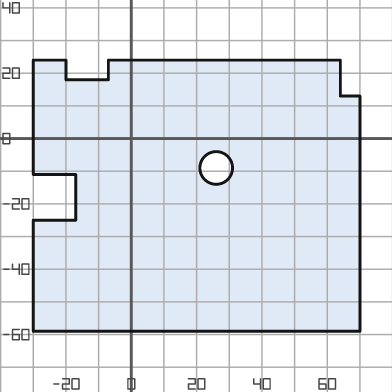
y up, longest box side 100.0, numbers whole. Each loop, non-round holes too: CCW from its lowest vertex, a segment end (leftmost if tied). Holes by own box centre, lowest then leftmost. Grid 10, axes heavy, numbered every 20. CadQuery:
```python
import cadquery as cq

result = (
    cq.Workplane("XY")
    .moveTo(-30.0, -59.0)
    .lineTo(70.0, -59.0)
    .lineTo(70.0, 13.0)
    .lineTo(64.0, 13.0)
    .lineTo(64.0, 24.0)
    .lineTo(-7.0, 24.0)
    .lineTo(-7.0, 18.0)
    .lineTo(-20.0, 18.0)
    .lineTo(-20.0, 24.0)
    .lineTo(-30.0, 24.0)
    .lineTo(-30.0, -11.0)
    .lineTo(-17.0, -11.0)
    .lineTo(-17.0, -25.0)
    .lineTo(-30.0, -25.0)
    .close()
    .moveTo(26.0, -9.0)
    .circle(5.0)
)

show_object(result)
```